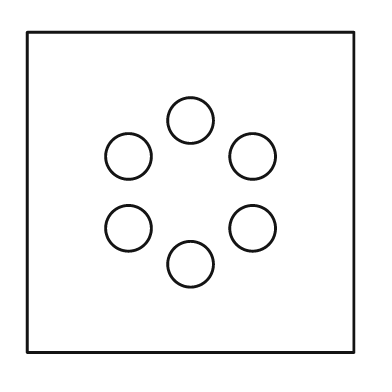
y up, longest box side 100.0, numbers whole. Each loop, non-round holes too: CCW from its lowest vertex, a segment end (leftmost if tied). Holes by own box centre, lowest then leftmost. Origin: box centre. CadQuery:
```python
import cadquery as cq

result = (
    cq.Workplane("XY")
    .moveTo(-50.0, -49.0)
    .lineTo(50.0, -49.0)
    .lineTo(50.0, 49.0)
    .lineTo(-50.0, 49.0)
    .close()
    .moveTo(0.0, -22.0)
    .circle(7.0)
    .moveTo(-19.0, -11.0)
    .circle(7.0)
    .moveTo(19.0, -11.0)
    .circle(7.0)
    .moveTo(-19.0, 11.0)
    .circle(7.0)
    .moveTo(19.0, 11.0)
    .circle(7.0)
    .moveTo(0.0, 22.0)
    .circle(7.0)
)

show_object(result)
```